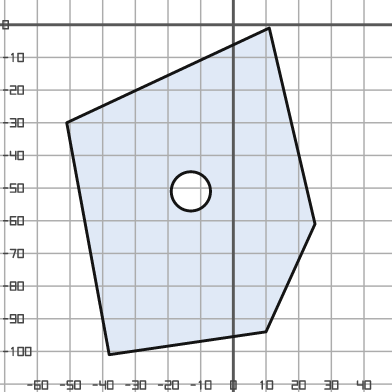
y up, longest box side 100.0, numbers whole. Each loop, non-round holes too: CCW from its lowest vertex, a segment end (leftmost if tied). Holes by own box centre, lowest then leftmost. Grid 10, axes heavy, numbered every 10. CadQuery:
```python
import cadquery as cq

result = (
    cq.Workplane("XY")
    .moveTo(-38.0, -101.0)
    .lineTo(10.0, -94.0)
    .lineTo(25.0, -61.0)
    .lineTo(11.0, -1.0)
    .lineTo(-51.0, -30.0)
    .close()
    .moveTo(-13.0, -51.0)
    .circle(6.0)
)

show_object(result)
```